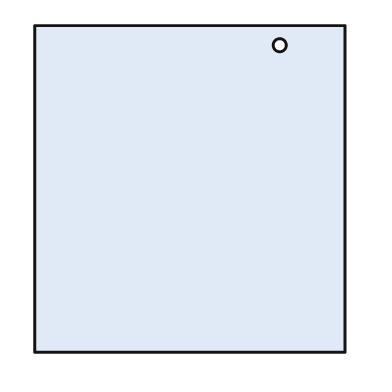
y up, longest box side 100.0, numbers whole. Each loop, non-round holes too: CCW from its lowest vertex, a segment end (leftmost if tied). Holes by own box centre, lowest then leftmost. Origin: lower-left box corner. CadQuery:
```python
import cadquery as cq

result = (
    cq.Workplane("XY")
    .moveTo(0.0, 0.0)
    .lineTo(95.0, 0.0)
    .lineTo(95.0, 100.0)
    .lineTo(0.0, 100.0)
    .close()
    .moveTo(75.0, 94.0)
    .circle(2.0)
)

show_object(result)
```